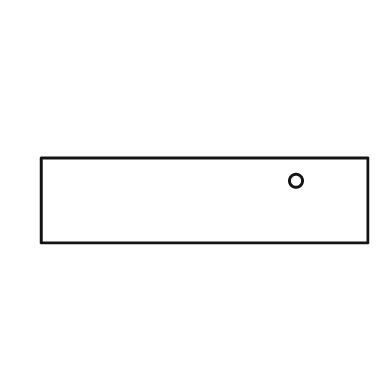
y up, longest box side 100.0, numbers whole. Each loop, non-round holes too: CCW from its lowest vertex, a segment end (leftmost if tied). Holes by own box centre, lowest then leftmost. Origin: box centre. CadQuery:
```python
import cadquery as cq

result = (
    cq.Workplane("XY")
    .moveTo(-50.0, -13.0)
    .lineTo(50.0, -13.0)
    .lineTo(50.0, 13.0)
    .lineTo(-50.0, 13.0)
    .close()
    .moveTo(28.0, 6.0)
    .circle(2.0)
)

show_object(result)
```